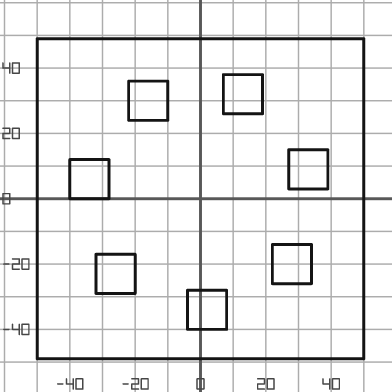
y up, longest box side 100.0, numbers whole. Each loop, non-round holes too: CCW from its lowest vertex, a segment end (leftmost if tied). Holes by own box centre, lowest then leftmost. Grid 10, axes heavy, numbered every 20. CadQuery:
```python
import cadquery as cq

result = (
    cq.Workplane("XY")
    .moveTo(-50.0, -49.0)
    .lineTo(50.0, -49.0)
    .lineTo(50.0, 49.0)
    .lineTo(-50.0, 49.0)
    .close()
    .moveTo(-4.0, -40.0)
    .lineTo(8.0, -40.0)
    .lineTo(8.0, -28.0)
    .lineTo(-4.0, -28.0)
    .close()
    .moveTo(-32.0, -29.0)
    .lineTo(-20.0, -29.0)
    .lineTo(-20.0, -17.0)
    .lineTo(-32.0, -17.0)
    .close()
    .moveTo(22.0, -26.0)
    .lineTo(34.0, -26.0)
    .lineTo(34.0, -14.0)
    .lineTo(22.0, -14.0)
    .close()
    .moveTo(-40.0, 0.0)
    .lineTo(-28.0, 0.0)
    .lineTo(-28.0, 12.0)
    .lineTo(-40.0, 12.0)
    .close()
    .moveTo(27.0, 3.0)
    .lineTo(39.0, 3.0)
    .lineTo(39.0, 15.0)
    .lineTo(27.0, 15.0)
    .close()
    .moveTo(-22.0, 24.0)
    .lineTo(-10.0, 24.0)
    .lineTo(-10.0, 36.0)
    .lineTo(-22.0, 36.0)
    .close()
    .moveTo(7.0, 26.0)
    .lineTo(19.0, 26.0)
    .lineTo(19.0, 38.0)
    .lineTo(7.0, 38.0)
    .close()
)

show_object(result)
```